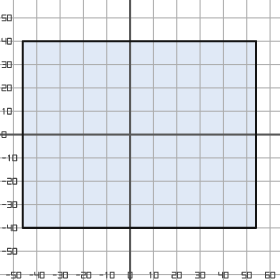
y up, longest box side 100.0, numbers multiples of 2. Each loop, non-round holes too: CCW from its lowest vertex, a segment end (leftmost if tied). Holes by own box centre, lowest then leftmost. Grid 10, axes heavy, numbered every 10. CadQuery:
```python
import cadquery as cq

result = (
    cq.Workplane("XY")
    .moveTo(-46.0, -40.0)
    .lineTo(54.0, -40.0)
    .lineTo(54.0, 40.0)
    .lineTo(-46.0, 40.0)
    .close()
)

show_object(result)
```